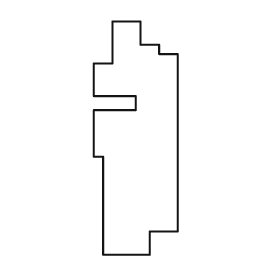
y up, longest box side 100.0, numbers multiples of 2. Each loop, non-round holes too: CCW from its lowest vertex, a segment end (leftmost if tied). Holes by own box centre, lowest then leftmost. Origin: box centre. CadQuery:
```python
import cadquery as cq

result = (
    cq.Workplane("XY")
    .moveTo(-14.0, -50.0)
    .lineTo(6.0, -50.0)
    .lineTo(6.0, -40.0)
    .lineTo(18.0, -40.0)
    .lineTo(18.0, 36.0)
    .lineTo(10.0, 36.0)
    .lineTo(10.0, 40.0)
    .lineTo(2.0, 40.0)
    .lineTo(2.0, 50.0)
    .lineTo(-10.0, 50.0)
    .lineTo(-10.0, 32.0)
    .lineTo(-18.0, 32.0)
    .lineTo(-18.0, 18.0)
    .lineTo(0.0, 18.0)
    .lineTo(0.0, 12.0)
    .lineTo(-18.0, 12.0)
    .lineTo(-18.0, -8.0)
    .lineTo(-14.0, -8.0)
    .close()
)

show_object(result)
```